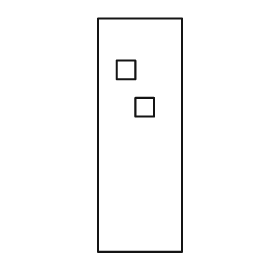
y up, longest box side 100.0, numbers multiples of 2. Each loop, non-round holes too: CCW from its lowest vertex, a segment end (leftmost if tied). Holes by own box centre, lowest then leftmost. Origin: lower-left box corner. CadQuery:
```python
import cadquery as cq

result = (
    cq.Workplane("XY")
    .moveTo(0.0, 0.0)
    .lineTo(36.0, 0.0)
    .lineTo(36.0, 100.0)
    .lineTo(0.0, 100.0)
    .close()
    .moveTo(16.0, 58.0)
    .lineTo(24.0, 58.0)
    .lineTo(24.0, 66.0)
    .lineTo(16.0, 66.0)
    .close()
    .moveTo(8.0, 74.0)
    .lineTo(16.0, 74.0)
    .lineTo(16.0, 82.0)
    .lineTo(8.0, 82.0)
    .close()
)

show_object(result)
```